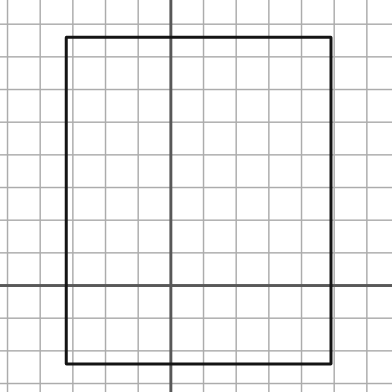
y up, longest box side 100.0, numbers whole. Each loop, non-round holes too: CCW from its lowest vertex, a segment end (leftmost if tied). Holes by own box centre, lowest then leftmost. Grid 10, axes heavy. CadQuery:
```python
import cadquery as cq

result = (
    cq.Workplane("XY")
    .moveTo(-32.0, -24.0)
    .lineTo(49.0, -24.0)
    .lineTo(49.0, 76.0)
    .lineTo(-32.0, 76.0)
    .close()
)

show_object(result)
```